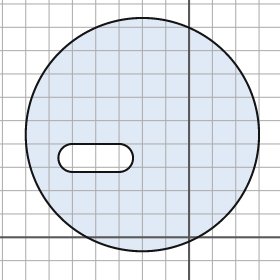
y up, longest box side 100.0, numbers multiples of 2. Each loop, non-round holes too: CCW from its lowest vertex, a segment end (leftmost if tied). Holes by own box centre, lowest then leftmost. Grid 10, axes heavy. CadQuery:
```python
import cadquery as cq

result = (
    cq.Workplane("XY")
    .moveTo(-20.0, 44.0)
    .circle(50.0)
    .moveTo(-50.0, 28.0)
    .lineTo(-30.0, 28.0)
    .threePointArc((-24.0, 34.0), (-30.0, 40.0))
    .lineTo(-50.0, 40.0)
    .threePointArc((-56.0, 34.0), (-50.0, 28.0))
    .close()
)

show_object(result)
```